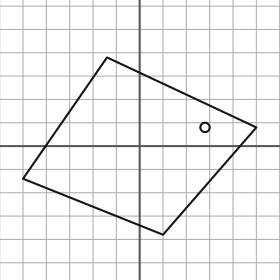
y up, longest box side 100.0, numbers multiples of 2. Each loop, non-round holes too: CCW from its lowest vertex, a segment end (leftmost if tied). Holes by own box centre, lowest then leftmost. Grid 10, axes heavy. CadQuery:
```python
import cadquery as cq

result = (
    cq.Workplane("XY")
    .moveTo(10.0, -38.0)
    .lineTo(50.0, 8.0)
    .lineTo(-14.0, 38.0)
    .lineTo(-50.0, -14.0)
    .close()
    .moveTo(28.0, 8.0)
    .circle(2.0)
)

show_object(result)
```